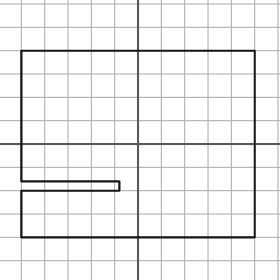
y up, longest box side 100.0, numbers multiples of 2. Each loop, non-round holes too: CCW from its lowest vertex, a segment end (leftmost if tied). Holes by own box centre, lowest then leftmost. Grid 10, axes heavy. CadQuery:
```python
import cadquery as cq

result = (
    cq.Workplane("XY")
    .moveTo(-50.0, -40.0)
    .lineTo(50.0, -40.0)
    .lineTo(50.0, 40.0)
    .lineTo(-50.0, 40.0)
    .lineTo(-50.0, -16.0)
    .lineTo(-8.0, -16.0)
    .lineTo(-8.0, -20.0)
    .lineTo(-50.0, -20.0)
    .close()
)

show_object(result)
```